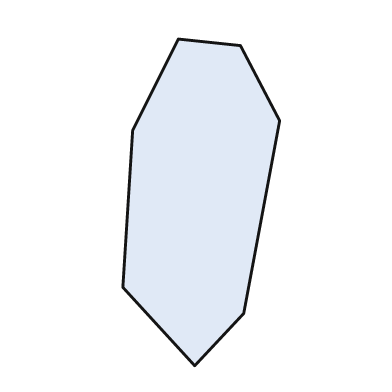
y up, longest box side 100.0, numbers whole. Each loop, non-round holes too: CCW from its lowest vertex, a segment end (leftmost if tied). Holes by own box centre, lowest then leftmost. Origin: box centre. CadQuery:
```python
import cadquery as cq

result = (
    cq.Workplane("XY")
    .moveTo(-2.0, -50.0)
    .lineTo(13.0, -34.0)
    .lineTo(24.0, 25.0)
    .lineTo(12.0, 48.0)
    .lineTo(-7.0, 50.0)
    .lineTo(-21.0, 22.0)
    .lineTo(-24.0, -26.0)
    .close()
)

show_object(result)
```